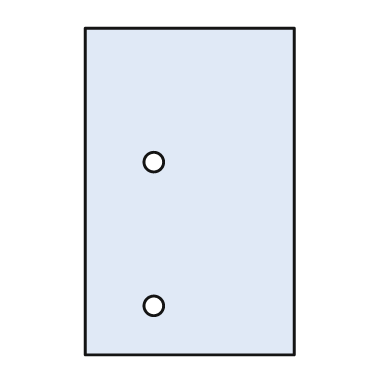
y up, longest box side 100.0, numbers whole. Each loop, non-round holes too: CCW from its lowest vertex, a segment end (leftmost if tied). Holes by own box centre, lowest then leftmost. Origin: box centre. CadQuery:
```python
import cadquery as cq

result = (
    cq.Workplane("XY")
    .moveTo(-32.0, -50.0)
    .lineTo(32.0, -50.0)
    .lineTo(32.0, 50.0)
    .lineTo(-32.0, 50.0)
    .close()
    .moveTo(-11.0, -35.0)
    .circle(3.0)
    .moveTo(-11.0, 9.0)
    .circle(3.0)
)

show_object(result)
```